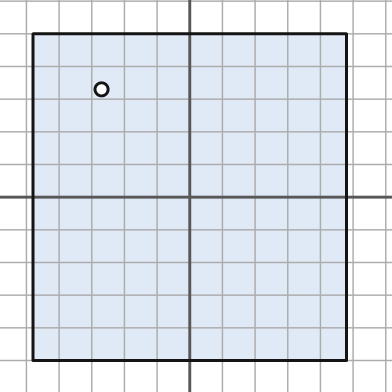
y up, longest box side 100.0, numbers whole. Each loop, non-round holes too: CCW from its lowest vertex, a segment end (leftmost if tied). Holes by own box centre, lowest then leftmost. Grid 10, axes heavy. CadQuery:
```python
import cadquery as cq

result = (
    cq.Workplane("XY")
    .moveTo(-48.0, -50.0)
    .lineTo(48.0, -50.0)
    .lineTo(48.0, 50.0)
    .lineTo(-48.0, 50.0)
    .close()
    .moveTo(-27.0, 33.0)
    .circle(2.0)
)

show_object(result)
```